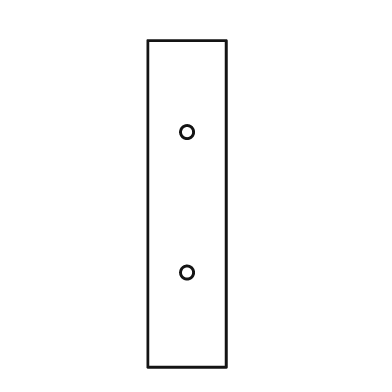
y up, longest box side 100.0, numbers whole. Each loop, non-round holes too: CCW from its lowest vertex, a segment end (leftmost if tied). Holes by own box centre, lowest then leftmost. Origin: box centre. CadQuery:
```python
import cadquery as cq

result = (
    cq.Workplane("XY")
    .moveTo(-12.0, -50.0)
    .lineTo(12.0, -50.0)
    .lineTo(12.0, 50.0)
    .lineTo(-12.0, 50.0)
    .close()
    .moveTo(0.0, -21.0)
    .circle(2.0)
    .moveTo(0.0, 22.0)
    .circle(2.0)
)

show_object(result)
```